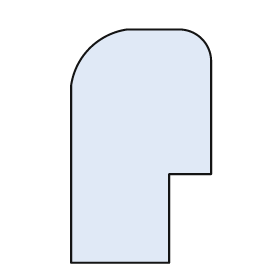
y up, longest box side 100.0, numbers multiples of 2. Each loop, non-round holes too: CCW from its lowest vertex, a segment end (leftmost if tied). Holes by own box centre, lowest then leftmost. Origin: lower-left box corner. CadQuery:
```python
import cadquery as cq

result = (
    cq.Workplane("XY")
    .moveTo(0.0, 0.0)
    .lineTo(42.0, 0.0)
    .lineTo(42.0, 38.0)
    .lineTo(60.0, 38.0)
    .lineTo(60.0, 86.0)
    .threePointArc((56.0, 96.0), (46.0, 100.0))
    .lineTo(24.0, 100.0)
    .threePointArc((8.0, 92.0), (0.0, 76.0))
    .close()
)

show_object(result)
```